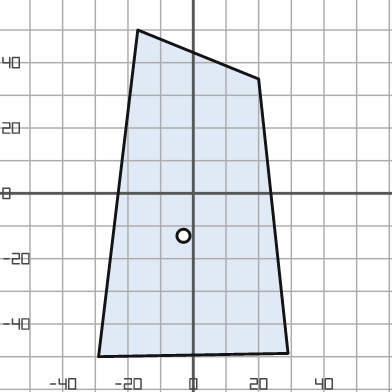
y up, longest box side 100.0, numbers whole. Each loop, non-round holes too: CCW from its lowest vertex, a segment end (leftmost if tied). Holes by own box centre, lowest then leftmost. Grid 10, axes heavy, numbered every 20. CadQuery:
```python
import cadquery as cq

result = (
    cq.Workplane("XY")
    .moveTo(-29.0, -50.0)
    .lineTo(29.0, -49.0)
    .lineTo(20.0, 35.0)
    .lineTo(-17.0, 50.0)
    .close()
    .moveTo(-3.0, -13.0)
    .circle(2.0)
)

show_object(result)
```